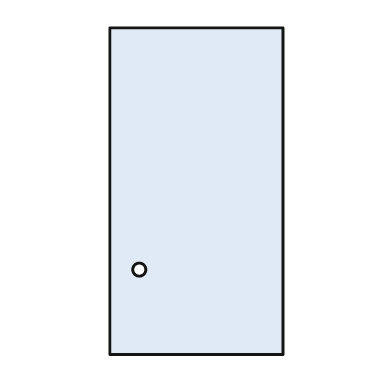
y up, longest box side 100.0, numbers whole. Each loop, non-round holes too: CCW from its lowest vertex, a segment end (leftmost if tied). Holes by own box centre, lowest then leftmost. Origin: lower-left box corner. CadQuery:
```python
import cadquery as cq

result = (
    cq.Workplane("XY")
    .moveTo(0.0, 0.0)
    .lineTo(53.0, 0.0)
    .lineTo(53.0, 100.0)
    .lineTo(0.0, 100.0)
    .close()
    .moveTo(9.0, 26.0)
    .circle(2.0)
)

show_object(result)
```